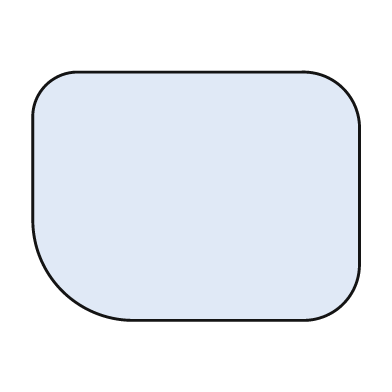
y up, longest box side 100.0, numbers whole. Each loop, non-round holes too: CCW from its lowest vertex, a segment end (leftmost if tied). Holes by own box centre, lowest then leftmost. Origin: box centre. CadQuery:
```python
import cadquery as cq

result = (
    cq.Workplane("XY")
    .moveTo(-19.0, -38.0)
    .lineTo(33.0, -38.0)
    .threePointArc((45.0, -33.0), (50.0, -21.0))
    .lineTo(50.0, 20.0)
    .threePointArc((45.0, 33.0), (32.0, 38.0))
    .lineTo(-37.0, 38.0)
    .threePointArc((-46.0, 34.0), (-50.0, 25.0))
    .lineTo(-50.0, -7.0)
    .threePointArc((-41.0, -29.0), (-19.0, -38.0))
    .close()
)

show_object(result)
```